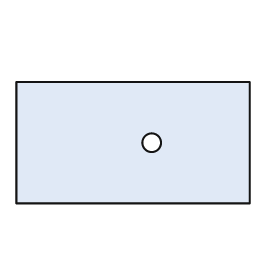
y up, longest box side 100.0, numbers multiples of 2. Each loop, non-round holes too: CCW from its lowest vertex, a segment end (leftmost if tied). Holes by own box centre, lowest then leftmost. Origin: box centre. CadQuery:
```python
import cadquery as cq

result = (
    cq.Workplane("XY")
    .moveTo(-50.0, -26.0)
    .lineTo(50.0, -26.0)
    .lineTo(50.0, 26.0)
    .lineTo(-50.0, 26.0)
    .close()
    .moveTo(8.0, 0.0)
    .circle(4.0)
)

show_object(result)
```